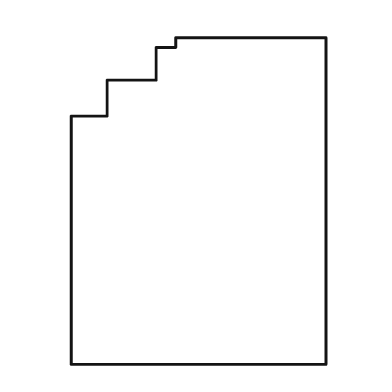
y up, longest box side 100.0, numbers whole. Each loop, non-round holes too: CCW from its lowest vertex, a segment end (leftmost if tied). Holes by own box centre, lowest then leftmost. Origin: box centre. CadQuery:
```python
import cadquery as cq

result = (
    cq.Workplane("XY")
    .moveTo(-39.0, -50.0)
    .lineTo(39.0, -50.0)
    .lineTo(39.0, 50.0)
    .lineTo(-7.0, 50.0)
    .lineTo(-7.0, 47.0)
    .lineTo(-13.0, 47.0)
    .lineTo(-13.0, 37.0)
    .lineTo(-28.0, 37.0)
    .lineTo(-28.0, 26.0)
    .lineTo(-39.0, 26.0)
    .close()
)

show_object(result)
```